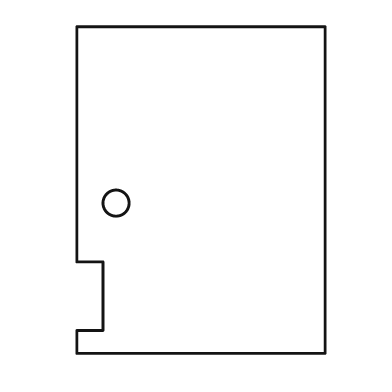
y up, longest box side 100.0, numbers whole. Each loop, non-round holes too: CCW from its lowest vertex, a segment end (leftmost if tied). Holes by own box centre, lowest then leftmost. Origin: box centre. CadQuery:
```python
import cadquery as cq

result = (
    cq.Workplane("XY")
    .moveTo(-38.0, -50.0)
    .lineTo(38.0, -50.0)
    .lineTo(38.0, 50.0)
    .lineTo(-38.0, 50.0)
    .lineTo(-38.0, -22.0)
    .lineTo(-30.0, -22.0)
    .lineTo(-30.0, -43.0)
    .lineTo(-38.0, -43.0)
    .close()
    .moveTo(-26.0, -4.0)
    .circle(4.0)
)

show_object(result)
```